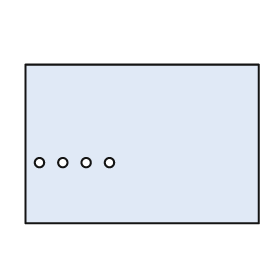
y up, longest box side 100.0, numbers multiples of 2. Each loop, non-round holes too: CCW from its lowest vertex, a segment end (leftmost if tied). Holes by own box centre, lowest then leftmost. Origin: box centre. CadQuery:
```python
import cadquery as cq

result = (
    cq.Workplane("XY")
    .moveTo(-50.0, -34.0)
    .lineTo(50.0, -34.0)
    .lineTo(50.0, 34.0)
    .lineTo(-50.0, 34.0)
    .close()
    .moveTo(-44.0, -8.0)
    .circle(2.0)
    .moveTo(-34.0, -8.0)
    .circle(2.0)
    .moveTo(-24.0, -8.0)
    .circle(2.0)
    .moveTo(-14.0, -8.0)
    .circle(2.0)
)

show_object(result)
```